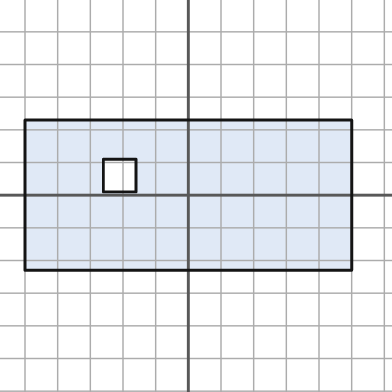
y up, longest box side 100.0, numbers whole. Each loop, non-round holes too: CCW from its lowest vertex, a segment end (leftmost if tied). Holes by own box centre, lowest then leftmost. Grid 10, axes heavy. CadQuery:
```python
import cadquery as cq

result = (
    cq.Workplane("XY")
    .moveTo(-50.0, -23.0)
    .lineTo(50.0, -23.0)
    .lineTo(50.0, 23.0)
    .lineTo(-50.0, 23.0)
    .close()
    .moveTo(-26.0, 1.0)
    .lineTo(-16.0, 1.0)
    .lineTo(-16.0, 11.0)
    .lineTo(-26.0, 11.0)
    .close()
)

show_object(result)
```